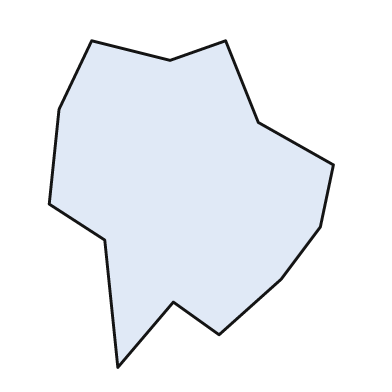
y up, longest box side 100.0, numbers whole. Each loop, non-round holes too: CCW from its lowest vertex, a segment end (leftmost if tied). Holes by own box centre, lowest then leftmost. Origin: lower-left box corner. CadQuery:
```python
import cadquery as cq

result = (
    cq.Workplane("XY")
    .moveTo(21.0, 0.0)
    .lineTo(38.0, 20.0)
    .lineTo(52.0, 10.0)
    .lineTo(71.0, 27.0)
    .lineTo(83.0, 43.0)
    .lineTo(87.0, 62.0)
    .lineTo(64.0, 75.0)
    .lineTo(54.0, 100.0)
    .lineTo(37.0, 94.0)
    .lineTo(13.0, 100.0)
    .lineTo(3.0, 79.0)
    .lineTo(0.0, 50.0)
    .lineTo(17.0, 39.0)
    .close()
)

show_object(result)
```